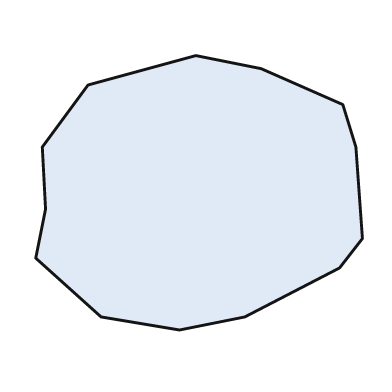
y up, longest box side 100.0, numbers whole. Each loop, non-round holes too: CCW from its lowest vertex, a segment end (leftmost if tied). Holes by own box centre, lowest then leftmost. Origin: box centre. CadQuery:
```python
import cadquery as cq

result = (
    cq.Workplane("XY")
    .moveTo(-6.0, -42.0)
    .lineTo(14.0, -38.0)
    .lineTo(43.0, -23.0)
    .lineTo(50.0, -14.0)
    .lineTo(48.0, 14.0)
    .lineTo(44.0, 27.0)
    .lineTo(19.0, 38.0)
    .lineTo(-1.0, 42.0)
    .lineTo(-34.0, 33.0)
    .lineTo(-48.0, 14.0)
    .lineTo(-47.0, -5.0)
    .lineTo(-50.0, -20.0)
    .lineTo(-30.0, -38.0)
    .close()
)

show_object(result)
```